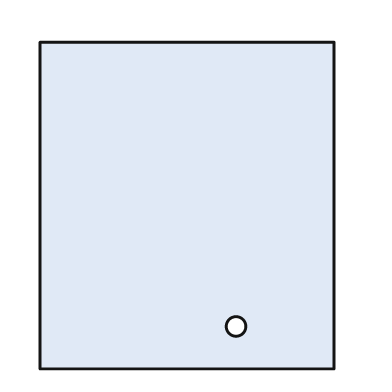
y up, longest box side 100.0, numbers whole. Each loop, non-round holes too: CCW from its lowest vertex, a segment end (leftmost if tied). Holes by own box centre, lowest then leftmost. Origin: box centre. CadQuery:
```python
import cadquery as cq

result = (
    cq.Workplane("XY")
    .moveTo(-45.0, -50.0)
    .lineTo(45.0, -50.0)
    .lineTo(45.0, 50.0)
    .lineTo(-45.0, 50.0)
    .close()
    .moveTo(15.0, -37.0)
    .circle(3.0)
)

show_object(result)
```